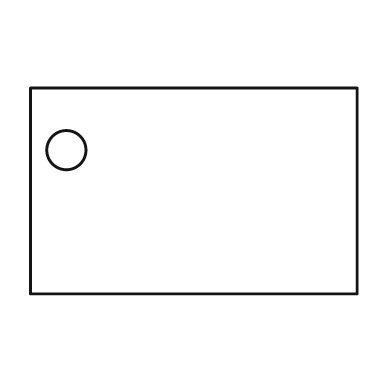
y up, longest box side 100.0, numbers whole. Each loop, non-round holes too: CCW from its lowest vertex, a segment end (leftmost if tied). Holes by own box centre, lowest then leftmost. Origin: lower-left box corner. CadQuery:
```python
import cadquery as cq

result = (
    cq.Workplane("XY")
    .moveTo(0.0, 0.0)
    .lineTo(100.0, 0.0)
    .lineTo(100.0, 63.0)
    .lineTo(0.0, 63.0)
    .close()
    .moveTo(11.0, 44.0)
    .circle(6.0)
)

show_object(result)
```